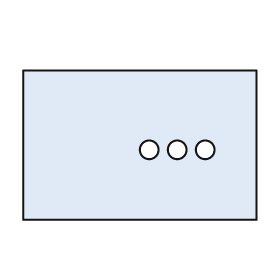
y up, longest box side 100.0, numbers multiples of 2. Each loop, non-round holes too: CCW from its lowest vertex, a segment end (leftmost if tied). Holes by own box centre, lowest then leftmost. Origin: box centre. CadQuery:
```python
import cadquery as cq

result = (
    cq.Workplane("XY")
    .moveTo(-50.0, -32.0)
    .lineTo(50.0, -32.0)
    .lineTo(50.0, 32.0)
    .lineTo(-50.0, 32.0)
    .close()
    .moveTo(4.0, -2.0)
    .circle(4.0)
    .moveTo(16.0, -2.0)
    .circle(4.0)
    .moveTo(28.0, -2.0)
    .circle(4.0)
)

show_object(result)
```